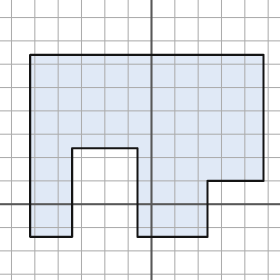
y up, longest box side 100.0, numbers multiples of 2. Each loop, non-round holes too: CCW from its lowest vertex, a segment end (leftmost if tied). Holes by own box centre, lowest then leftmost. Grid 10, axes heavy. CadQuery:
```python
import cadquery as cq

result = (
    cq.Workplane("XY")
    .moveTo(-52.0, -14.0)
    .lineTo(-34.0, -14.0)
    .lineTo(-34.0, 24.0)
    .lineTo(-6.0, 24.0)
    .lineTo(-6.0, -14.0)
    .lineTo(24.0, -14.0)
    .lineTo(24.0, 10.0)
    .lineTo(48.0, 10.0)
    .lineTo(48.0, 64.0)
    .lineTo(-52.0, 64.0)
    .close()
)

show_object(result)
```